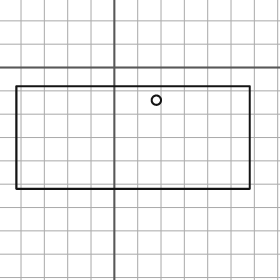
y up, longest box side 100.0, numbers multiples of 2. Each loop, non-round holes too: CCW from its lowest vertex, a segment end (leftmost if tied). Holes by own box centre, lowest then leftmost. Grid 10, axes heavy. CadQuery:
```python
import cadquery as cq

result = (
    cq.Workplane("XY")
    .moveTo(-42.0, -52.0)
    .lineTo(58.0, -52.0)
    .lineTo(58.0, -8.0)
    .lineTo(-42.0, -8.0)
    .close()
    .moveTo(18.0, -14.0)
    .circle(2.0)
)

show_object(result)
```